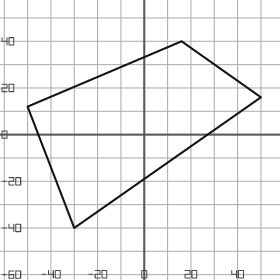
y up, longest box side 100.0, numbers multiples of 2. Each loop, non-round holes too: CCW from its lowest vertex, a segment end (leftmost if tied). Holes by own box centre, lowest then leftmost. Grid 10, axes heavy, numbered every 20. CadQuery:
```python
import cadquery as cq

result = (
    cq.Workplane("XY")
    .moveTo(-30.0, -40.0)
    .lineTo(50.0, 16.0)
    .lineTo(16.0, 40.0)
    .lineTo(-50.0, 12.0)
    .close()
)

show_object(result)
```